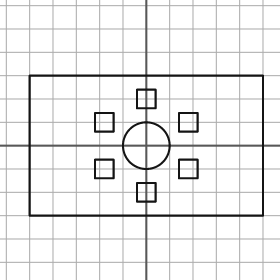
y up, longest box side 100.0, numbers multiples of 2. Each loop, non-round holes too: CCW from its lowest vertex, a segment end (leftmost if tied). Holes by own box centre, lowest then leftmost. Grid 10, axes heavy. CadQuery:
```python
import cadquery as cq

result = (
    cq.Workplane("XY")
    .moveTo(-50.0, -30.0)
    .lineTo(50.0, -30.0)
    .lineTo(50.0, 30.0)
    .lineTo(-50.0, 30.0)
    .close()
    .moveTo(-4.0, -24.0)
    .lineTo(4.0, -24.0)
    .lineTo(4.0, -16.0)
    .lineTo(-4.0, -16.0)
    .close()
    .moveTo(-22.0, -14.0)
    .lineTo(-14.0, -14.0)
    .lineTo(-14.0, -6.0)
    .lineTo(-22.0, -6.0)
    .close()
    .moveTo(14.0, -14.0)
    .lineTo(22.0, -14.0)
    .lineTo(22.0, -6.0)
    .lineTo(14.0, -6.0)
    .close()
    .moveTo(0.0, 0.0)
    .circle(10.0)
    .moveTo(-22.0, 6.0)
    .lineTo(-14.0, 6.0)
    .lineTo(-14.0, 14.0)
    .lineTo(-22.0, 14.0)
    .close()
    .moveTo(14.0, 6.0)
    .lineTo(22.0, 6.0)
    .lineTo(22.0, 14.0)
    .lineTo(14.0, 14.0)
    .close()
    .moveTo(-4.0, 16.0)
    .lineTo(4.0, 16.0)
    .lineTo(4.0, 24.0)
    .lineTo(-4.0, 24.0)
    .close()
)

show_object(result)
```